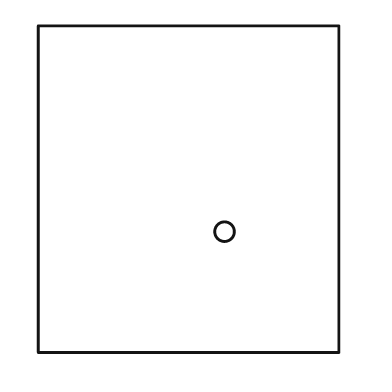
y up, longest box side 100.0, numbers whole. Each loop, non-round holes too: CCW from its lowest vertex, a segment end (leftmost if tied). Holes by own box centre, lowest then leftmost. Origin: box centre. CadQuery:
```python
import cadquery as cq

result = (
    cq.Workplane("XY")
    .moveTo(-46.0, -50.0)
    .lineTo(46.0, -50.0)
    .lineTo(46.0, 50.0)
    .lineTo(-46.0, 50.0)
    .close()
    .moveTo(11.0, -13.0)
    .circle(3.0)
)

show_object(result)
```